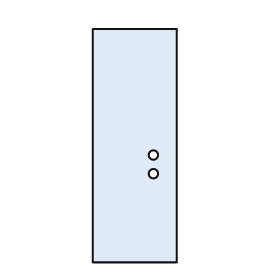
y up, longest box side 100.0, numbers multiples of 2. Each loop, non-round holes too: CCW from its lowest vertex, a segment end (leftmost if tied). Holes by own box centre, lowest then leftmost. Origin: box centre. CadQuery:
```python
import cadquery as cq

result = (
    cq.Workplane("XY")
    .moveTo(-18.0, -50.0)
    .lineTo(18.0, -50.0)
    .lineTo(18.0, 50.0)
    .lineTo(-18.0, 50.0)
    .close()
    .moveTo(8.0, -12.0)
    .circle(2.0)
    .moveTo(8.0, -4.0)
    .circle(2.0)
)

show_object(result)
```